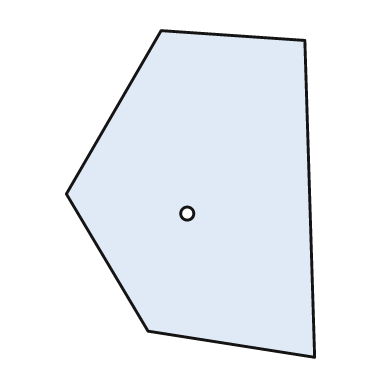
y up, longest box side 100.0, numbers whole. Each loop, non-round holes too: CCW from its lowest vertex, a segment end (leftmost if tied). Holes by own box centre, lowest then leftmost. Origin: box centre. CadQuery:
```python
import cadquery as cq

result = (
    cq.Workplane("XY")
    .moveTo(38.0, -50.0)
    .lineTo(35.0, 47.0)
    .lineTo(-9.0, 50.0)
    .lineTo(-38.0, 0.0)
    .lineTo(-13.0, -42.0)
    .close()
    .moveTo(-1.0, -6.0)
    .circle(2.0)
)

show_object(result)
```